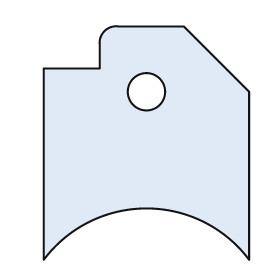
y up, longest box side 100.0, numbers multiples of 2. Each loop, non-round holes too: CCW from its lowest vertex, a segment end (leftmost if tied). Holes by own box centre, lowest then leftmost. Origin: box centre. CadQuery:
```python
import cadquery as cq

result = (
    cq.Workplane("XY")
    .moveTo(-44.0, -50.0)
    .threePointArc((0.0, -28.0), (44.0, -50.0))
    .lineTo(44.0, 22.0)
    .lineTo(16.0, 50.0)
    .lineTo(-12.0, 50.0)
    .threePointArc((-18.0, 48.0), (-20.0, 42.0))
    .lineTo(-20.0, 32.0)
    .lineTo(-44.0, 32.0)
    .close()
    .moveTo(0.0, 22.0)
    .circle(8.0)
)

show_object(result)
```